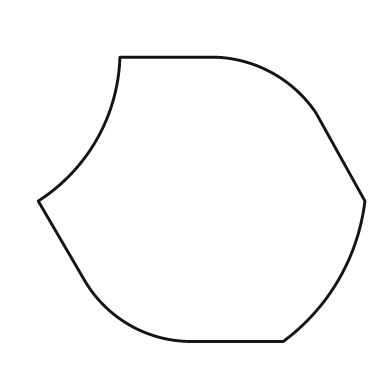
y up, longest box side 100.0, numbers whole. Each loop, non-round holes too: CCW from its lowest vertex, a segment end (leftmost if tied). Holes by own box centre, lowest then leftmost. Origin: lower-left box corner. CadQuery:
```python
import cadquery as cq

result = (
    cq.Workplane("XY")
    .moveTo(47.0, 0.0)
    .lineTo(75.0, 0.0)
    .threePointArc((92.0, 19.0), (100.0, 43.0))
    .lineTo(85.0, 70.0)
    .threePointArc((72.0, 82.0), (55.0, 87.0))
    .lineTo(25.0, 87.0)
    .threePointArc((18.0, 62.0), (0.0, 43.0))
    .lineTo(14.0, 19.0)
    .threePointArc((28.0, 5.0), (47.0, 0.0))
    .close()
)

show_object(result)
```